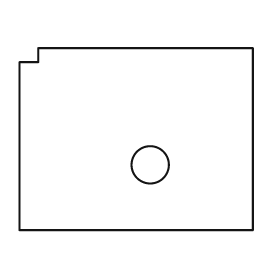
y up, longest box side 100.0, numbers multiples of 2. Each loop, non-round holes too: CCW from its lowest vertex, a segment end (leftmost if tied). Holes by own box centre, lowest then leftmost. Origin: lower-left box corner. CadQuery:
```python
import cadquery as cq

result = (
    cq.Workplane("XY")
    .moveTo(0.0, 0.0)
    .lineTo(100.0, 0.0)
    .lineTo(100.0, 78.0)
    .lineTo(8.0, 78.0)
    .lineTo(8.0, 72.0)
    .lineTo(0.0, 72.0)
    .close()
    .moveTo(56.0, 28.0)
    .circle(8.0)
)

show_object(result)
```